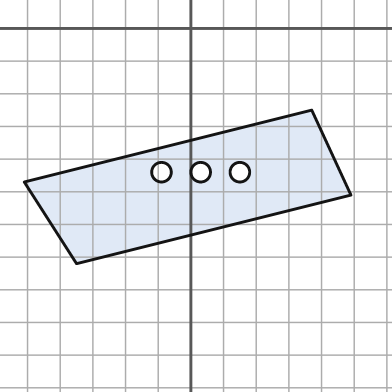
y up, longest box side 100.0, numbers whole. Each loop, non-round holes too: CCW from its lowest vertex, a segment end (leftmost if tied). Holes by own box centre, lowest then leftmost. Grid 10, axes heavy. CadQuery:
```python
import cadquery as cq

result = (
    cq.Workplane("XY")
    .moveTo(-35.0, -72.0)
    .lineTo(49.0, -51.0)
    .lineTo(37.0, -25.0)
    .lineTo(-51.0, -47.0)
    .close()
    .moveTo(-9.0, -44.0)
    .circle(3.0)
    .moveTo(3.0, -44.0)
    .circle(3.0)
    .moveTo(15.0, -44.0)
    .circle(3.0)
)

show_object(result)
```